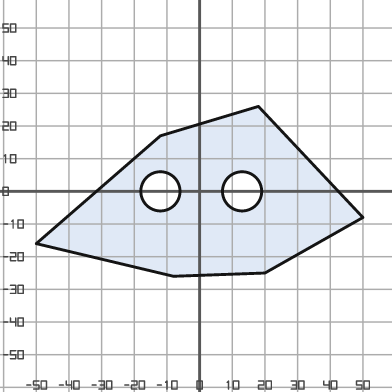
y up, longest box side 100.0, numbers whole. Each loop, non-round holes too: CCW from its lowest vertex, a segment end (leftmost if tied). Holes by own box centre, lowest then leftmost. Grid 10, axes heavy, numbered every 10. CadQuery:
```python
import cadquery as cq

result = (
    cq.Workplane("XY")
    .moveTo(-8.0, -26.0)
    .lineTo(20.0, -25.0)
    .lineTo(50.0, -8.0)
    .lineTo(18.0, 26.0)
    .lineTo(-12.0, 17.0)
    .lineTo(-50.0, -16.0)
    .close()
    .moveTo(-12.0, 0.0)
    .circle(6.0)
    .moveTo(13.0, 0.0)
    .circle(6.0)
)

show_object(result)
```